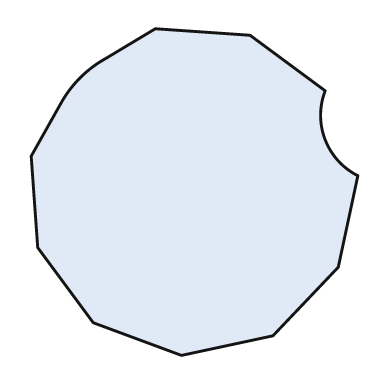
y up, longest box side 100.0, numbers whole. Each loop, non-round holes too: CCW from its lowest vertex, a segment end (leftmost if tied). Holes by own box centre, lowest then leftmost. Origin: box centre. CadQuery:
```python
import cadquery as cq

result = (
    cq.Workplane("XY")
    .moveTo(-4.0, -50.0)
    .lineTo(24.0, -44.0)
    .lineTo(44.0, -23.0)
    .lineTo(50.0, 5.0)
    .threePointArc((40.0, 16.0), (40.0, 31.0))
    .lineTo(17.0, 48.0)
    .lineTo(-12.0, 50.0)
    .lineTo(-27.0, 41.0)
    .threePointArc((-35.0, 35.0), (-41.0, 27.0))
    .lineTo(-50.0, 11.0)
    .lineTo(-48.0, -17.0)
    .lineTo(-31.0, -40.0)
    .close()
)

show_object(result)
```